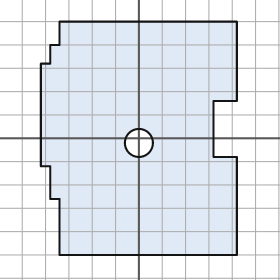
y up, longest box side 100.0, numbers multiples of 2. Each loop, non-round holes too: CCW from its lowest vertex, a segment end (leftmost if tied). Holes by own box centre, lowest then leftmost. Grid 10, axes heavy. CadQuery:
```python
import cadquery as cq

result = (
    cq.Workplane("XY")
    .moveTo(-34.0, -50.0)
    .lineTo(42.0, -50.0)
    .lineTo(42.0, -8.0)
    .lineTo(32.0, -8.0)
    .lineTo(32.0, 16.0)
    .lineTo(42.0, 16.0)
    .lineTo(42.0, 50.0)
    .lineTo(-34.0, 50.0)
    .lineTo(-34.0, 40.0)
    .lineTo(-38.0, 40.0)
    .lineTo(-38.0, 32.0)
    .lineTo(-42.0, 32.0)
    .lineTo(-42.0, -12.0)
    .lineTo(-38.0, -12.0)
    .lineTo(-38.0, -26.0)
    .lineTo(-34.0, -26.0)
    .close()
    .moveTo(0.0, -2.0)
    .circle(6.0)
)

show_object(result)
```